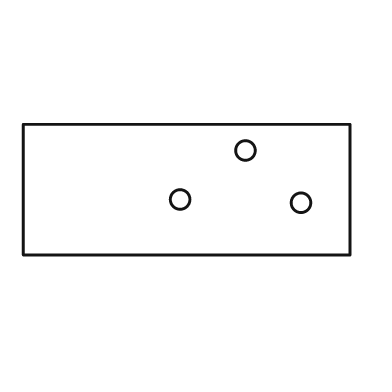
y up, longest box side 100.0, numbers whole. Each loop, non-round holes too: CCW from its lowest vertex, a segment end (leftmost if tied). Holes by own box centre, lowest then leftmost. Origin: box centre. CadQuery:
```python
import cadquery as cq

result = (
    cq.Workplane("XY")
    .moveTo(-50.0, -20.0)
    .lineTo(50.0, -20.0)
    .lineTo(50.0, 20.0)
    .lineTo(-50.0, 20.0)
    .close()
    .moveTo(35.0, -4.0)
    .circle(3.0)
    .moveTo(-2.0, -3.0)
    .circle(3.0)
    .moveTo(18.0, 12.0)
    .circle(3.0)
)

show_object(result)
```